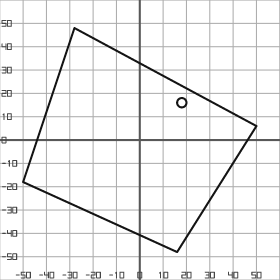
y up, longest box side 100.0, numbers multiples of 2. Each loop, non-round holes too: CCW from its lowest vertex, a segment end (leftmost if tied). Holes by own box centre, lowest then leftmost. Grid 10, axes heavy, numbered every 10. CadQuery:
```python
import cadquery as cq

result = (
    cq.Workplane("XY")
    .moveTo(16.0, -48.0)
    .lineTo(50.0, 6.0)
    .lineTo(-28.0, 48.0)
    .lineTo(-50.0, -18.0)
    .close()
    .moveTo(18.0, 16.0)
    .circle(2.0)
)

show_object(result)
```